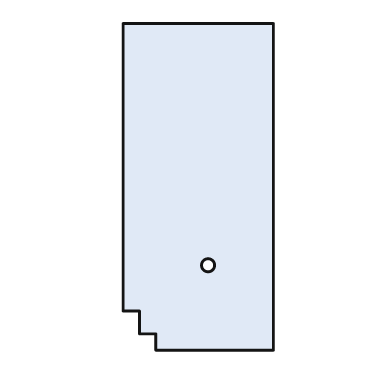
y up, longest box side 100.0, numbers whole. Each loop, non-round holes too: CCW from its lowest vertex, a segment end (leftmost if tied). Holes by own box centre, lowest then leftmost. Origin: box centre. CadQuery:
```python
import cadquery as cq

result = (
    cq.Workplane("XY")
    .moveTo(-13.0, -50.0)
    .lineTo(23.0, -50.0)
    .lineTo(23.0, 50.0)
    .lineTo(-23.0, 50.0)
    .lineTo(-23.0, -38.0)
    .lineTo(-18.0, -38.0)
    .lineTo(-18.0, -45.0)
    .lineTo(-13.0, -45.0)
    .close()
    .moveTo(3.0, -24.0)
    .circle(2.0)
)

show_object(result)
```